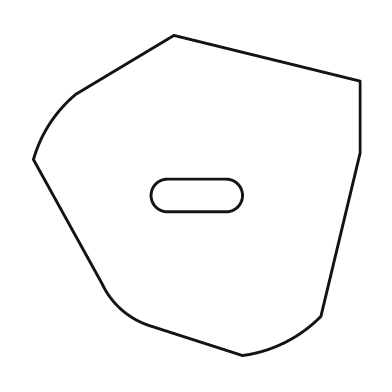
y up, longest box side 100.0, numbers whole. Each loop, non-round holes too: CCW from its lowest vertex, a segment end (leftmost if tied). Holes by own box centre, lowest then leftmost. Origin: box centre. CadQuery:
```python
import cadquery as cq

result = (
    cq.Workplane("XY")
    .moveTo(14.0, -49.0)
    .threePointArc((27.0, -45.0), (38.0, -37.0))
    .lineTo(50.0, 13.0)
    .lineTo(50.0, 35.0)
    .lineTo(-7.0, 49.0)
    .lineTo(-37.0, 31.0)
    .threePointArc((-45.0, 22.0), (-50.0, 11.0))
    .lineTo(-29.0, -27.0)
    .threePointArc((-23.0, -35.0), (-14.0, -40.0))
    .close()
    .moveTo(-9.0, -5.0)
    .lineTo(9.0, -5.0)
    .threePointArc((14.0, 0.0), (9.0, 5.0))
    .lineTo(-9.0, 5.0)
    .threePointArc((-14.0, 0.0), (-9.0, -5.0))
    .close()
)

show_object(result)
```